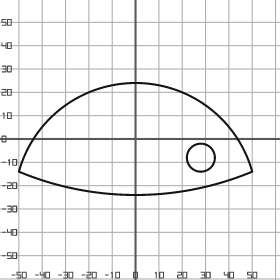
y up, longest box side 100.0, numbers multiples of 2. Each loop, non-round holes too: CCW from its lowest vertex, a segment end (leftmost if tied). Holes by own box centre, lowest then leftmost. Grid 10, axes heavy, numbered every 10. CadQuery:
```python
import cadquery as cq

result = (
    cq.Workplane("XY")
    .moveTo(-50.0, -14.0)
    .threePointArc((0.0, -24.0), (50.0, -14.0))
    .threePointArc((0.0, 24.0), (-50.0, -14.0))
    .close()
    .moveTo(28.0, -8.0)
    .circle(6.0)
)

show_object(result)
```